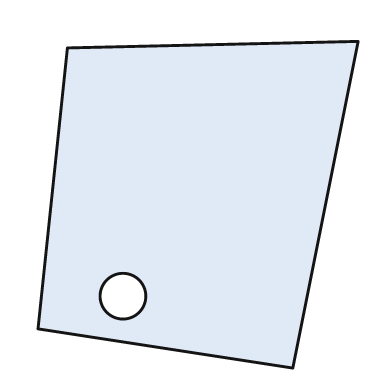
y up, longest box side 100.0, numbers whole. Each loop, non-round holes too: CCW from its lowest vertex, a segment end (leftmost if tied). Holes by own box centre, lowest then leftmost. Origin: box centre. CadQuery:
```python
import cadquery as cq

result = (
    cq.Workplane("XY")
    .moveTo(29.0, -50.0)
    .lineTo(49.0, 50.0)
    .lineTo(-40.0, 48.0)
    .lineTo(-49.0, -38.0)
    .close()
    .moveTo(-23.0, -28.0)
    .circle(7.0)
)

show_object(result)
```